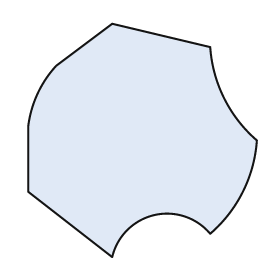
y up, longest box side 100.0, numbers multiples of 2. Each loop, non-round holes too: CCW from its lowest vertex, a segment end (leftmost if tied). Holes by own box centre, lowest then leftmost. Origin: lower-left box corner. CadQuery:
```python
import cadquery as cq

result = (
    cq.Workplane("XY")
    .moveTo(36.0, 0.0)
    .threePointArc((54.0, 18.0), (78.0, 10.0))
    .threePointArc((92.0, 28.0), (98.0, 50.0))
    .threePointArc((84.0, 68.0), (78.0, 90.0))
    .lineTo(36.0, 100.0)
    .lineTo(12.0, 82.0)
    .threePointArc((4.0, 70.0), (0.0, 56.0))
    .lineTo(0.0, 28.0)
    .close()
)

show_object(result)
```